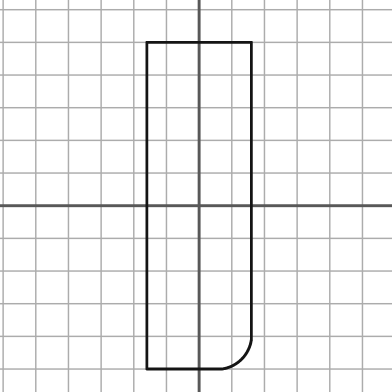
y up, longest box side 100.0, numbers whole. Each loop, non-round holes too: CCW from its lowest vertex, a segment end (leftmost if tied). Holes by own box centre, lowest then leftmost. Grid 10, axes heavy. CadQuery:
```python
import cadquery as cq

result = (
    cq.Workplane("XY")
    .moveTo(-16.0, -50.0)
    .lineTo(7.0, -50.0)
    .threePointArc((13.0, -47.0), (16.0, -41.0))
    .lineTo(16.0, 50.0)
    .lineTo(-16.0, 50.0)
    .close()
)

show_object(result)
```